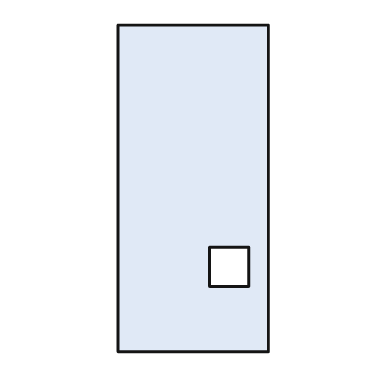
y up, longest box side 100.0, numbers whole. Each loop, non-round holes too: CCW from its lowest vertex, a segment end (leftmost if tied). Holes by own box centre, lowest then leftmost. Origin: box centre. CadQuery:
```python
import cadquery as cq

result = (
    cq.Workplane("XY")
    .moveTo(-23.0, -50.0)
    .lineTo(23.0, -50.0)
    .lineTo(23.0, 50.0)
    .lineTo(-23.0, 50.0)
    .close()
    .moveTo(5.0, -30.0)
    .lineTo(17.0, -30.0)
    .lineTo(17.0, -18.0)
    .lineTo(5.0, -18.0)
    .close()
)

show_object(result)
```